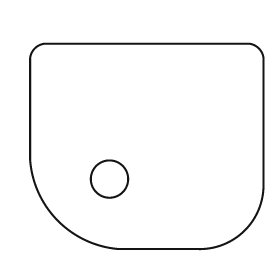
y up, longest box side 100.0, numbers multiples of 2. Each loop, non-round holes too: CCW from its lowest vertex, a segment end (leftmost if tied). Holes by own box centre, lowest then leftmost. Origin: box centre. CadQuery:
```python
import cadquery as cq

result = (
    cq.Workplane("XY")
    .moveTo(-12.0, -44.0)
    .lineTo(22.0, -44.0)
    .threePointArc((42.0, -36.0), (50.0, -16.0))
    .lineTo(50.0, 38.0)
    .threePointArc((48.0, 42.0), (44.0, 44.0))
    .lineTo(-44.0, 44.0)
    .threePointArc((-48.0, 42.0), (-50.0, 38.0))
    .lineTo(-50.0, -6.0)
    .threePointArc((-38.0, -32.0), (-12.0, -44.0))
    .close()
    .moveTo(-16.0, -14.0)
    .circle(8.0)
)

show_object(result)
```